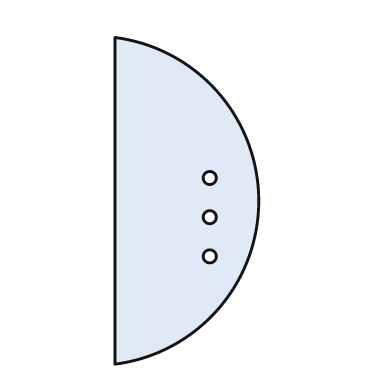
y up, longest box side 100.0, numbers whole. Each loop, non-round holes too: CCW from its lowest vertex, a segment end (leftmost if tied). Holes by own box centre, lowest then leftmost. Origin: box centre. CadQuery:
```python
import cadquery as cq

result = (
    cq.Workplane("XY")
    .moveTo(-22.0, -50.0)
    .threePointArc((22.0, 0.0), (-22.0, 50.0))
    .close()
    .moveTo(7.0, -17.0)
    .circle(2.0)
    .moveTo(7.0, -5.0)
    .circle(2.0)
    .moveTo(7.0, 7.0)
    .circle(2.0)
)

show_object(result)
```